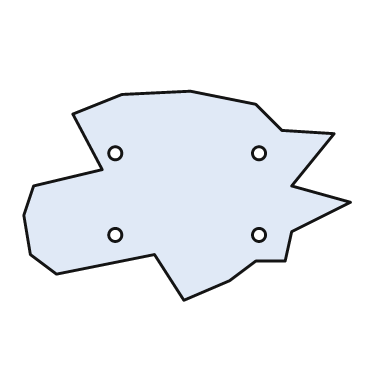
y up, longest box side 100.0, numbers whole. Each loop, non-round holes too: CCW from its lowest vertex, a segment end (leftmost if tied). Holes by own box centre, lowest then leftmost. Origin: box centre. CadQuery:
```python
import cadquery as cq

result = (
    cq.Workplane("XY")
    .moveTo(-1.0, -32.0)
    .lineTo(13.0, -26.0)
    .lineTo(21.0, -20.0)
    .lineTo(30.0, -20.0)
    .lineTo(32.0, -11.0)
    .lineTo(50.0, -2.0)
    .lineTo(32.0, 3.0)
    .lineTo(45.0, 19.0)
    .lineTo(29.0, 20.0)
    .lineTo(21.0, 28.0)
    .lineTo(1.0, 32.0)
    .lineTo(-20.0, 31.0)
    .lineTo(-35.0, 25.0)
    .lineTo(-26.0, 8.0)
    .lineTo(-47.0, 3.0)
    .lineTo(-50.0, -6.0)
    .lineTo(-48.0, -18.0)
    .lineTo(-40.0, -24.0)
    .lineTo(-10.0, -18.0)
    .close()
    .moveTo(-22.0, -12.0)
    .circle(2.0)
    .moveTo(22.0, -12.0)
    .circle(2.0)
    .moveTo(-22.0, 13.0)
    .circle(2.0)
    .moveTo(22.0, 13.0)
    .circle(2.0)
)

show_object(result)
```